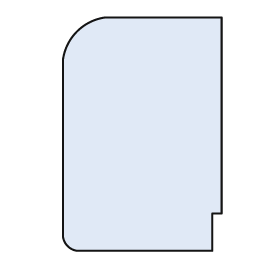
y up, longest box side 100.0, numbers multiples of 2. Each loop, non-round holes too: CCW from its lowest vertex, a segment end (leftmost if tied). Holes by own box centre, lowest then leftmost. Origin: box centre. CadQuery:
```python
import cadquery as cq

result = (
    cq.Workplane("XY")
    .moveTo(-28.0, -50.0)
    .lineTo(30.0, -50.0)
    .lineTo(30.0, -34.0)
    .lineTo(34.0, -34.0)
    .lineTo(34.0, 50.0)
    .lineTo(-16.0, 50.0)
    .threePointArc((-28.0, 44.0), (-34.0, 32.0))
    .lineTo(-34.0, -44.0)
    .threePointArc((-32.0, -48.0), (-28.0, -50.0))
    .close()
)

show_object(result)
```